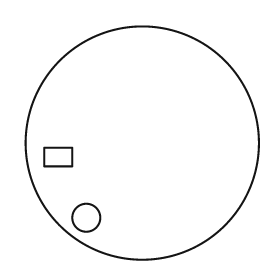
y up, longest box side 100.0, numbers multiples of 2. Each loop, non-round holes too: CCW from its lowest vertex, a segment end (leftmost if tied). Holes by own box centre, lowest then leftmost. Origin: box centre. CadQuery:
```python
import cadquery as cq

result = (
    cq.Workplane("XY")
    .moveTo(0.0, 0.0)
    .circle(50.0)
    .moveTo(-24.0, -32.0)
    .circle(6.0)
    .moveTo(-42.0, -10.0)
    .lineTo(-30.0, -10.0)
    .lineTo(-30.0, -2.0)
    .lineTo(-42.0, -2.0)
    .close()
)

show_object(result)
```